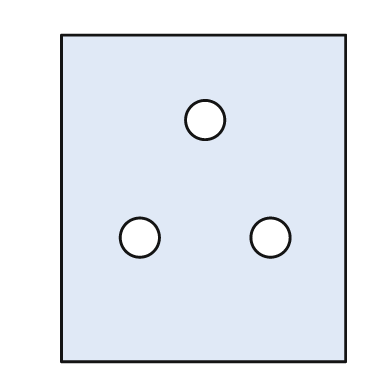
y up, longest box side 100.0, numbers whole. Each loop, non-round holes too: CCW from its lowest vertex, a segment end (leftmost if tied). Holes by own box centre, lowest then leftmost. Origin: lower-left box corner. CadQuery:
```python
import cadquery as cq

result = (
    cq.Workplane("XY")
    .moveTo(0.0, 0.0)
    .lineTo(87.0, 0.0)
    .lineTo(87.0, 100.0)
    .lineTo(0.0, 100.0)
    .close()
    .moveTo(24.0, 38.0)
    .circle(6.0)
    .moveTo(64.0, 38.0)
    .circle(6.0)
    .moveTo(44.0, 74.0)
    .circle(6.0)
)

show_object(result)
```